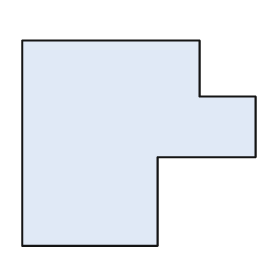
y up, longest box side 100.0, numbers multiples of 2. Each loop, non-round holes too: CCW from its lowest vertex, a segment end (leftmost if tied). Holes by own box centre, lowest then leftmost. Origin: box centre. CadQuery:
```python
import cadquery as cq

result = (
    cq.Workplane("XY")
    .moveTo(-50.0, -44.0)
    .lineTo(8.0, -44.0)
    .lineTo(8.0, -6.0)
    .lineTo(50.0, -6.0)
    .lineTo(50.0, 20.0)
    .lineTo(26.0, 20.0)
    .lineTo(26.0, 44.0)
    .lineTo(-50.0, 44.0)
    .close()
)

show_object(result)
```